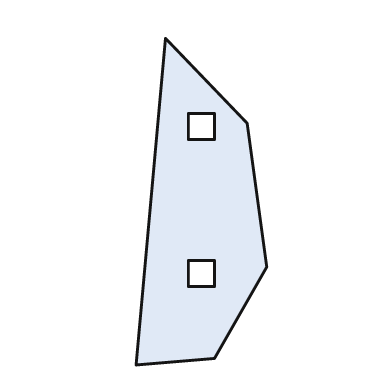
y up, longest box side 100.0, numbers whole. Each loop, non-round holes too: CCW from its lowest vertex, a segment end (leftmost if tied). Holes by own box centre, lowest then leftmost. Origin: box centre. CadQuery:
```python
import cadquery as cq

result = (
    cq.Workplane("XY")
    .moveTo(-20.0, -50.0)
    .lineTo(4.0, -48.0)
    .lineTo(20.0, -20.0)
    .lineTo(14.0, 24.0)
    .lineTo(-11.0, 50.0)
    .close()
    .moveTo(-4.0, -26.0)
    .lineTo(4.0, -26.0)
    .lineTo(4.0, -18.0)
    .lineTo(-4.0, -18.0)
    .close()
    .moveTo(-4.0, 19.0)
    .lineTo(4.0, 19.0)
    .lineTo(4.0, 27.0)
    .lineTo(-4.0, 27.0)
    .close()
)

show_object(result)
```